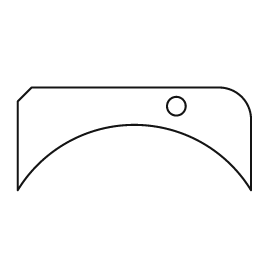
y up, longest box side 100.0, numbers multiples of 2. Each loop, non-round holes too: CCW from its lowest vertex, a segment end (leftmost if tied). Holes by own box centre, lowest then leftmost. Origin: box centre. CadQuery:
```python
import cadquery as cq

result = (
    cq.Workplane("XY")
    .moveTo(-50.0, -22.0)
    .threePointArc((0.0, 6.0), (50.0, -22.0))
    .lineTo(50.0, 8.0)
    .threePointArc((46.0, 18.0), (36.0, 22.0))
    .lineTo(-44.0, 22.0)
    .lineTo(-50.0, 16.0)
    .close()
    .moveTo(18.0, 14.0)
    .circle(4.0)
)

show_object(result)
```